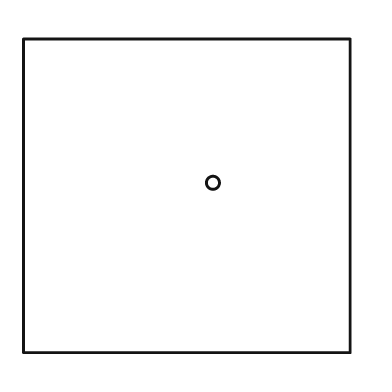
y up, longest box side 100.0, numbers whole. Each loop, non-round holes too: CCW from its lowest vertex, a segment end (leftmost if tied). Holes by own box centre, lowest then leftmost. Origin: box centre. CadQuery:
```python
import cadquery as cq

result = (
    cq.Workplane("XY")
    .moveTo(-50.0, -48.0)
    .lineTo(50.0, -48.0)
    .lineTo(50.0, 48.0)
    .lineTo(-50.0, 48.0)
    .close()
    .moveTo(8.0, 4.0)
    .circle(2.0)
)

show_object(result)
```